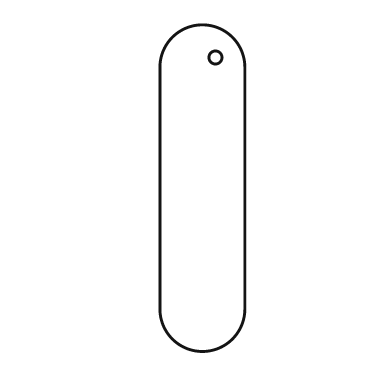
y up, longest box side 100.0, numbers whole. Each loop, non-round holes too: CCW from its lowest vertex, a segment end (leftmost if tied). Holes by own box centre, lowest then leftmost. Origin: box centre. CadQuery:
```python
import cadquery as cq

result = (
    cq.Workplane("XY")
    .moveTo(-13.0, -37.0)
    .threePointArc((0.0, -50.0), (13.0, -37.0))
    .lineTo(13.0, 37.0)
    .threePointArc((0.0, 50.0), (-13.0, 37.0))
    .close()
    .moveTo(4.0, 40.0)
    .circle(2.0)
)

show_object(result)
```